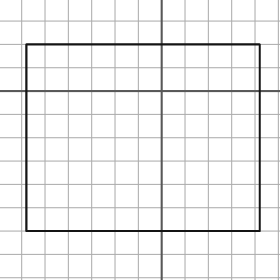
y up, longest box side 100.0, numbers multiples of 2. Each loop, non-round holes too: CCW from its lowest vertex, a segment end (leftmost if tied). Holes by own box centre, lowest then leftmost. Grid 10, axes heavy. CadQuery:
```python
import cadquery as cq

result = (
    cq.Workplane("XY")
    .moveTo(-58.0, -60.0)
    .lineTo(42.0, -60.0)
    .lineTo(42.0, 20.0)
    .lineTo(-58.0, 20.0)
    .close()
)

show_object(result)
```